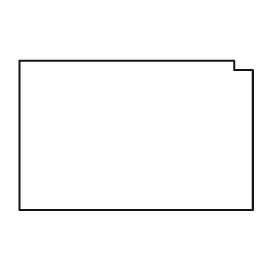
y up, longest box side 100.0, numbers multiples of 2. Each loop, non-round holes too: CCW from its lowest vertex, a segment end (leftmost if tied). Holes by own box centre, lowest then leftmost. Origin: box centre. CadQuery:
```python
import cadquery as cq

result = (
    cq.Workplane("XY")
    .moveTo(-50.0, -32.0)
    .lineTo(50.0, -32.0)
    .lineTo(50.0, 28.0)
    .lineTo(42.0, 28.0)
    .lineTo(42.0, 32.0)
    .lineTo(-50.0, 32.0)
    .close()
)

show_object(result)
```